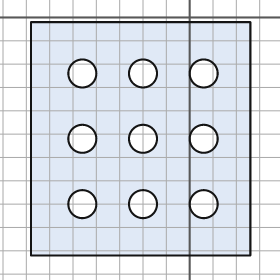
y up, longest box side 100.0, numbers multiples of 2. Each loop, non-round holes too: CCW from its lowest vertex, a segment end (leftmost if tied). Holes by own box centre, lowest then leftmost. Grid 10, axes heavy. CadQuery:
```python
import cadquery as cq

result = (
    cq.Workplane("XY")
    .moveTo(-68.0, -102.0)
    .lineTo(26.0, -102.0)
    .lineTo(26.0, -2.0)
    .lineTo(-68.0, -2.0)
    .close()
    .moveTo(-46.0, -80.0)
    .circle(6.0)
    .moveTo(-20.0, -80.0)
    .circle(6.0)
    .moveTo(6.0, -80.0)
    .circle(6.0)
    .moveTo(-46.0, -52.0)
    .circle(6.0)
    .moveTo(-20.0, -52.0)
    .circle(6.0)
    .moveTo(6.0, -52.0)
    .circle(6.0)
    .moveTo(-46.0, -24.0)
    .circle(6.0)
    .moveTo(-20.0, -24.0)
    .circle(6.0)
    .moveTo(6.0, -24.0)
    .circle(6.0)
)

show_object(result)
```